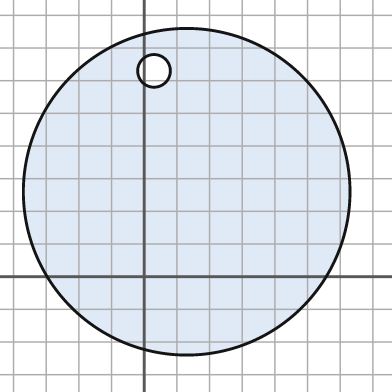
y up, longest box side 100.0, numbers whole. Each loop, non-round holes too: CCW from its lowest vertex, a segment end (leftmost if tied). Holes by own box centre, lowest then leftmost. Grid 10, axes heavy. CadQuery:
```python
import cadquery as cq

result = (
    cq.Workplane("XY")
    .moveTo(13.0, 26.0)
    .circle(50.0)
    .moveTo(3.0, 63.0)
    .circle(5.0)
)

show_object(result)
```